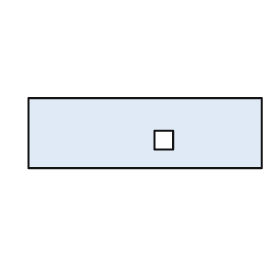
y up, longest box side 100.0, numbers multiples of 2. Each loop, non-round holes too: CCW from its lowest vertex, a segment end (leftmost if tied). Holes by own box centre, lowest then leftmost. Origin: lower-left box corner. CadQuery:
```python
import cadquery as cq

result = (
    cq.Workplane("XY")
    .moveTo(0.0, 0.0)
    .lineTo(100.0, 0.0)
    .lineTo(100.0, 30.0)
    .lineTo(0.0, 30.0)
    .close()
    .moveTo(54.0, 8.0)
    .lineTo(62.0, 8.0)
    .lineTo(62.0, 16.0)
    .lineTo(54.0, 16.0)
    .close()
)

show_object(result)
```